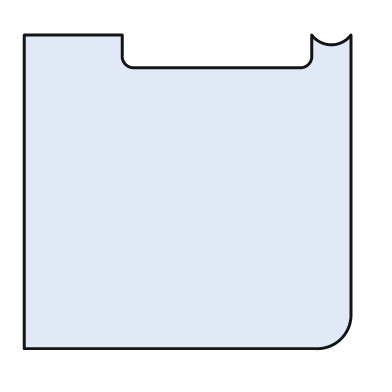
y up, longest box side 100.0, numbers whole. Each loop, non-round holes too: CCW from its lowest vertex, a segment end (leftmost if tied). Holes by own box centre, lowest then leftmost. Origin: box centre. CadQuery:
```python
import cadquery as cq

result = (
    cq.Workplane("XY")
    .moveTo(-50.0, -48.0)
    .lineTo(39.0, -48.0)
    .threePointArc((47.0, -45.0), (50.0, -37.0))
    .lineTo(50.0, 48.0)
    .threePointArc((44.0, 45.0), (38.0, 48.0))
    .lineTo(38.0, 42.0)
    .threePointArc((37.0, 39.0), (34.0, 38.0))
    .lineTo(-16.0, 38.0)
    .threePointArc((-19.0, 39.0), (-20.0, 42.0))
    .lineTo(-20.0, 48.0)
    .lineTo(-50.0, 48.0)
    .close()
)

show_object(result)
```